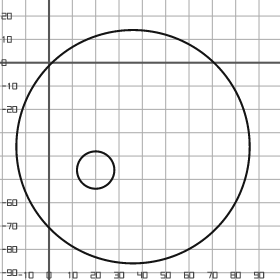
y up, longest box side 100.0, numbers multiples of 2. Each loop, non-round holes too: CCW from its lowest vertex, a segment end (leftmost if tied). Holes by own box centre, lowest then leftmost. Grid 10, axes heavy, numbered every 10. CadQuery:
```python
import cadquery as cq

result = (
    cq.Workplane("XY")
    .moveTo(36.0, -36.0)
    .circle(50.0)
    .moveTo(20.0, -46.0)
    .circle(8.0)
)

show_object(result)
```